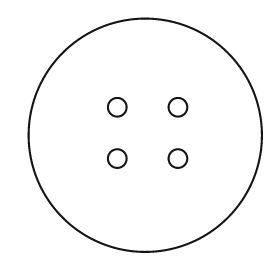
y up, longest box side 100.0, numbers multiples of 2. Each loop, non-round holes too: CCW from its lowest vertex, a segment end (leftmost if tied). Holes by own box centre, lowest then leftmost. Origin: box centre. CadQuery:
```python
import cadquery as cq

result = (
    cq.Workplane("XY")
    .moveTo(0.0, 0.0)
    .circle(50.0)
    .moveTo(-12.0, -10.0)
    .circle(4.0)
    .moveTo(14.0, -10.0)
    .circle(4.0)
    .moveTo(-12.0, 12.0)
    .circle(4.0)
    .moveTo(14.0, 12.0)
    .circle(4.0)
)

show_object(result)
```